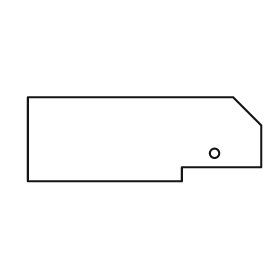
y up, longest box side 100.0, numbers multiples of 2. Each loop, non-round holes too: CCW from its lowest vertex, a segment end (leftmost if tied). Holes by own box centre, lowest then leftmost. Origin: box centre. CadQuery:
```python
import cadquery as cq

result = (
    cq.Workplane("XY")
    .moveTo(-50.0, -18.0)
    .lineTo(16.0, -18.0)
    .lineTo(16.0, -12.0)
    .lineTo(50.0, -12.0)
    .lineTo(50.0, 6.0)
    .lineTo(38.0, 18.0)
    .lineTo(-50.0, 18.0)
    .close()
    .moveTo(30.0, -6.0)
    .circle(2.0)
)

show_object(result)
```